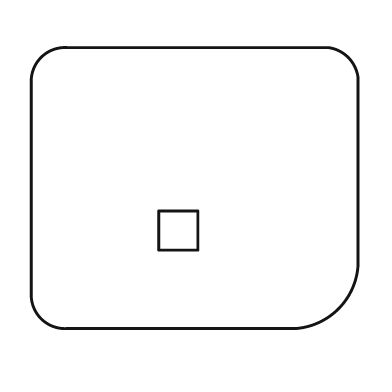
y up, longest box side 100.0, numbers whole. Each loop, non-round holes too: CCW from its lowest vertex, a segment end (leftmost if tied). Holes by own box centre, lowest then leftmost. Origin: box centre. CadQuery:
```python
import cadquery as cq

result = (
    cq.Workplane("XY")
    .moveTo(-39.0, -43.0)
    .lineTo(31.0, -43.0)
    .threePointArc((44.0, -37.0), (50.0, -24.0))
    .lineTo(50.0, 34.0)
    .threePointArc((47.0, 40.0), (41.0, 43.0))
    .lineTo(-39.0, 43.0)
    .threePointArc((-47.0, 40.0), (-50.0, 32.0))
    .lineTo(-50.0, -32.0)
    .threePointArc((-47.0, -40.0), (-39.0, -43.0))
    .close()
    .moveTo(-11.0, -19.0)
    .lineTo(1.0, -19.0)
    .lineTo(1.0, -7.0)
    .lineTo(-11.0, -7.0)
    .close()
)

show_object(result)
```